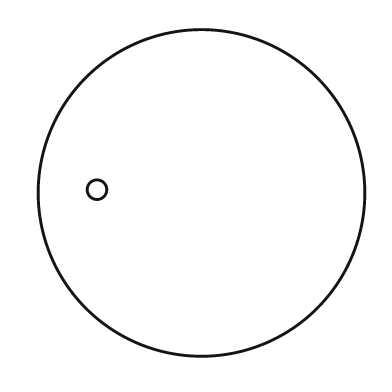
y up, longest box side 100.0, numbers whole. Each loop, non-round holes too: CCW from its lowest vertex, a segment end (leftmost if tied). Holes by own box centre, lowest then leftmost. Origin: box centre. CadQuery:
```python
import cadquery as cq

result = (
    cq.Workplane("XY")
    .moveTo(0.0, 0.0)
    .circle(50.0)
    .moveTo(-32.0, 1.0)
    .circle(3.0)
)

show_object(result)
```